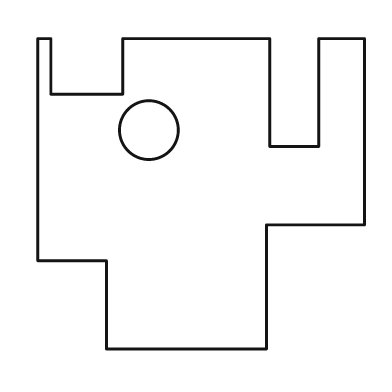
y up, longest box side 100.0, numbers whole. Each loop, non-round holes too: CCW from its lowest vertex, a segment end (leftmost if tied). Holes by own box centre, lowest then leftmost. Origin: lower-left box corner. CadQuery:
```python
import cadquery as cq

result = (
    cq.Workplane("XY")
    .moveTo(21.0, 0.0)
    .lineTo(70.0, 0.0)
    .lineTo(70.0, 38.0)
    .lineTo(100.0, 38.0)
    .lineTo(100.0, 95.0)
    .lineTo(86.0, 95.0)
    .lineTo(86.0, 62.0)
    .lineTo(71.0, 62.0)
    .lineTo(71.0, 95.0)
    .lineTo(26.0, 95.0)
    .lineTo(26.0, 78.0)
    .lineTo(4.0, 78.0)
    .lineTo(4.0, 95.0)
    .lineTo(0.0, 95.0)
    .lineTo(0.0, 27.0)
    .lineTo(21.0, 27.0)
    .close()
    .moveTo(34.0, 67.0)
    .circle(9.0)
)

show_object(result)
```